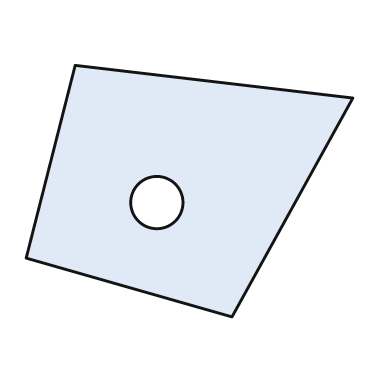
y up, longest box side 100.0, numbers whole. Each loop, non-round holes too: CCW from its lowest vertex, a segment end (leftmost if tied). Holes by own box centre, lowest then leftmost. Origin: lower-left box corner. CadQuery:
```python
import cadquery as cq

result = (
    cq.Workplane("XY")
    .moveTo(63.0, 0.0)
    .lineTo(100.0, 67.0)
    .lineTo(15.0, 77.0)
    .lineTo(0.0, 18.0)
    .close()
    .moveTo(40.0, 35.0)
    .circle(8.0)
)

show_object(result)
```